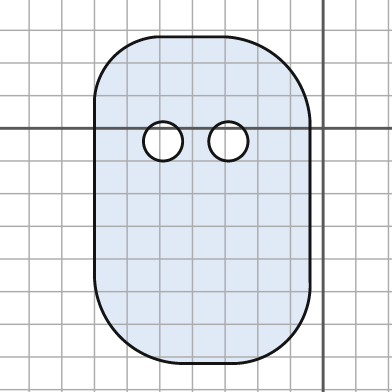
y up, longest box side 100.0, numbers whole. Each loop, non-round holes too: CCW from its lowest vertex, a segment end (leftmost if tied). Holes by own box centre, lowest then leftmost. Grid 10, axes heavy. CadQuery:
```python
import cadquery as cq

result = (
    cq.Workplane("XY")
    .moveTo(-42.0, -72.0)
    .lineTo(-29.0, -72.0)
    .threePointArc((-11.0, -65.0), (-4.0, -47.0))
    .lineTo(-4.0, 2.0)
    .threePointArc((-12.0, 20.0), (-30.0, 28.0))
    .lineTo(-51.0, 28.0)
    .threePointArc((-64.0, 22.0), (-70.0, 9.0))
    .lineTo(-70.0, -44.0)
    .threePointArc((-62.0, -64.0), (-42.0, -72.0))
    .close()
    .moveTo(-49.0, -4.0)
    .circle(6.0)
    .moveTo(-29.0, -4.0)
    .circle(6.0)
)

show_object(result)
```